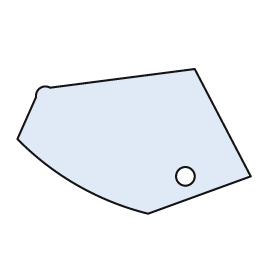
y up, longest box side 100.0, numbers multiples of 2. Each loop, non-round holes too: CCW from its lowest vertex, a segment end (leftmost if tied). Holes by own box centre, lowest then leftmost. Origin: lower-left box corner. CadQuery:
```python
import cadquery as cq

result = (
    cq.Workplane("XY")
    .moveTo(56.0, 0.0)
    .lineTo(100.0, 16.0)
    .lineTo(76.0, 62.0)
    .lineTo(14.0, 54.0)
    .threePointArc((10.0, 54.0), (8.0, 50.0))
    .lineTo(0.0, 32.0)
    .threePointArc((26.0, 12.0), (56.0, 0.0))
    .close()
    .moveTo(72.0, 16.0)
    .circle(4.0)
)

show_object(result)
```